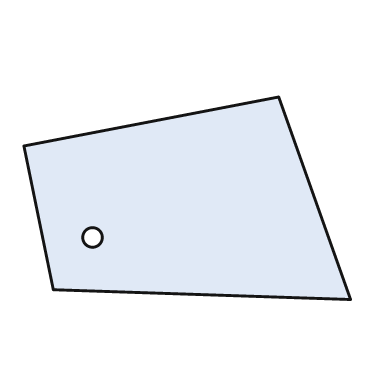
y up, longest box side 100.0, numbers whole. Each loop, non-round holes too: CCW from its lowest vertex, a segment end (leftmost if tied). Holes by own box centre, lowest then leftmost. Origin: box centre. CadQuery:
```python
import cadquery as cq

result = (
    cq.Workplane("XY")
    .moveTo(50.0, -31.0)
    .lineTo(28.0, 31.0)
    .lineTo(-50.0, 16.0)
    .lineTo(-41.0, -28.0)
    .close()
    .moveTo(-29.0, -12.0)
    .circle(3.0)
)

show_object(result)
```